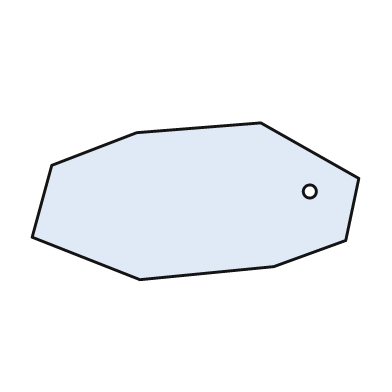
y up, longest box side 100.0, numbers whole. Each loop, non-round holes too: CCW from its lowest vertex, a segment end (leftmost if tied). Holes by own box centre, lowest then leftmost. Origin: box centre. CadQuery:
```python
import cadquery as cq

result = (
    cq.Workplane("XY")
    .moveTo(-17.0, -24.0)
    .lineTo(24.0, -20.0)
    .lineTo(46.0, -12.0)
    .lineTo(50.0, 7.0)
    .lineTo(20.0, 24.0)
    .lineTo(-18.0, 21.0)
    .lineTo(-44.0, 11.0)
    .lineTo(-50.0, -11.0)
    .close()
    .moveTo(35.0, 3.0)
    .circle(2.0)
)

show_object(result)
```